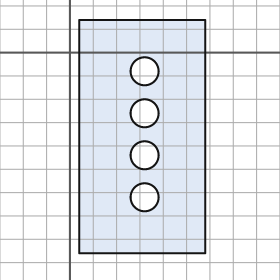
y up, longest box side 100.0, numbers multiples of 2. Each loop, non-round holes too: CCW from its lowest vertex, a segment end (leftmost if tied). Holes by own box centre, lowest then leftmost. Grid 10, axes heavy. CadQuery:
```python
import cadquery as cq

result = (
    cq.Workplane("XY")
    .moveTo(4.0, -86.0)
    .lineTo(58.0, -86.0)
    .lineTo(58.0, 14.0)
    .lineTo(4.0, 14.0)
    .close()
    .moveTo(32.0, -62.0)
    .circle(6.0)
    .moveTo(32.0, -44.0)
    .circle(6.0)
    .moveTo(32.0, -26.0)
    .circle(6.0)
    .moveTo(32.0, -8.0)
    .circle(6.0)
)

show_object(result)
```